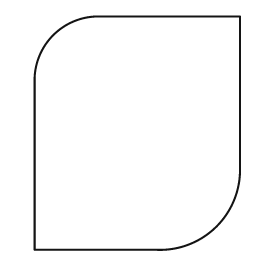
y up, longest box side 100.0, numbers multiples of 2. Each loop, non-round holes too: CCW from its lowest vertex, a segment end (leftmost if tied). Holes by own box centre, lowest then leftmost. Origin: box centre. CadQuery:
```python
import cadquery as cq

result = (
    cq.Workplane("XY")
    .moveTo(-44.0, -50.0)
    .lineTo(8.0, -50.0)
    .threePointArc((34.0, -40.0), (44.0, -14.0))
    .lineTo(44.0, 50.0)
    .lineTo(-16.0, 50.0)
    .threePointArc((-36.0, 42.0), (-44.0, 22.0))
    .close()
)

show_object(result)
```